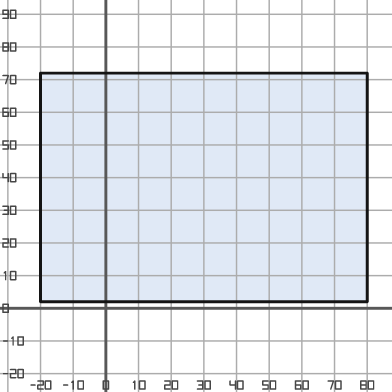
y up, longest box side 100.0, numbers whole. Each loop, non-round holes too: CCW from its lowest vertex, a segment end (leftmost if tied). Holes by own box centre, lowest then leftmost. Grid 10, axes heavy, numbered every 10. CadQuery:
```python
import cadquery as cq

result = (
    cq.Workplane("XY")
    .moveTo(-20.0, 2.0)
    .lineTo(80.0, 2.0)
    .lineTo(80.0, 72.0)
    .lineTo(-20.0, 72.0)
    .close()
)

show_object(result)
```